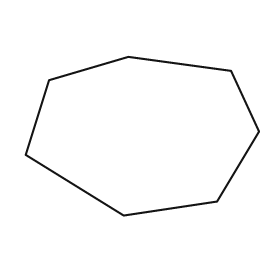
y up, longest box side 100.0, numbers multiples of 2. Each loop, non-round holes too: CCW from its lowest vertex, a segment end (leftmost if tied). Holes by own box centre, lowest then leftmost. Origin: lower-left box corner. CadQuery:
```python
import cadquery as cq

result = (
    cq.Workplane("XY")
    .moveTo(42.0, 0.0)
    .lineTo(82.0, 6.0)
    .lineTo(100.0, 36.0)
    .lineTo(88.0, 62.0)
    .lineTo(44.0, 68.0)
    .lineTo(10.0, 58.0)
    .lineTo(0.0, 26.0)
    .close()
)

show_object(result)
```